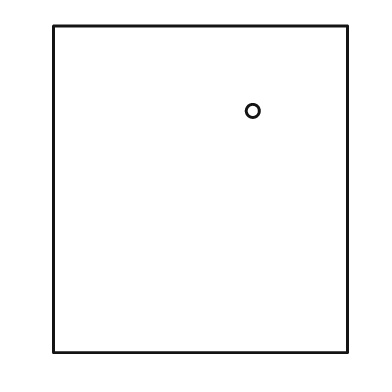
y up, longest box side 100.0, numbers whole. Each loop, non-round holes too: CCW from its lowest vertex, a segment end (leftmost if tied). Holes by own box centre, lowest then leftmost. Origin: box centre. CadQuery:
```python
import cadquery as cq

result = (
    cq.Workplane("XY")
    .moveTo(-45.0, -50.0)
    .lineTo(45.0, -50.0)
    .lineTo(45.0, 50.0)
    .lineTo(-45.0, 50.0)
    .close()
    .moveTo(16.0, 24.0)
    .circle(2.0)
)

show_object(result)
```